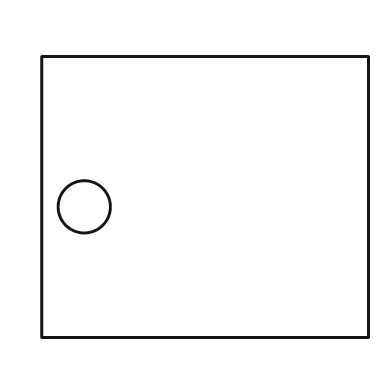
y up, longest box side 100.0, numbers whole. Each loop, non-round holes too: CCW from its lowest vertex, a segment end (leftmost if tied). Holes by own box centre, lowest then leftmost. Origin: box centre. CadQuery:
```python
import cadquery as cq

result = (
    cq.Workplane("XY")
    .moveTo(-50.0, -43.0)
    .lineTo(50.0, -43.0)
    .lineTo(50.0, 43.0)
    .lineTo(-50.0, 43.0)
    .close()
    .moveTo(-37.0, -3.0)
    .circle(8.0)
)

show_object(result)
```